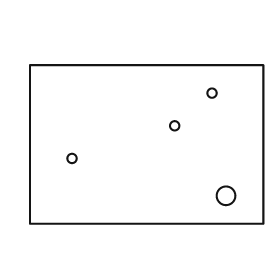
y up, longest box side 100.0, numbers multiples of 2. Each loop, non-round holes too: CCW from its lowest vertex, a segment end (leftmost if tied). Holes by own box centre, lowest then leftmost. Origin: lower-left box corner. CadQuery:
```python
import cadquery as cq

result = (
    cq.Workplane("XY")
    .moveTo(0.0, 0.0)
    .lineTo(100.0, 0.0)
    .lineTo(100.0, 68.0)
    .lineTo(0.0, 68.0)
    .close()
    .moveTo(84.0, 12.0)
    .circle(4.0)
    .moveTo(18.0, 28.0)
    .circle(2.0)
    .moveTo(62.0, 42.0)
    .circle(2.0)
    .moveTo(78.0, 56.0)
    .circle(2.0)
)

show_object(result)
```